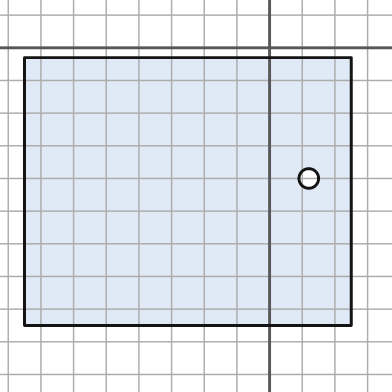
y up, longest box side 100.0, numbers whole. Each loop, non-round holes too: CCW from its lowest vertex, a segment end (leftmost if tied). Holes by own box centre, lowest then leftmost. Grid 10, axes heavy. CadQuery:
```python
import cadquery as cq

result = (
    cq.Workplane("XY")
    .moveTo(-75.0, -85.0)
    .lineTo(25.0, -85.0)
    .lineTo(25.0, -3.0)
    .lineTo(-75.0, -3.0)
    .close()
    .moveTo(12.0, -40.0)
    .circle(3.0)
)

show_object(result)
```